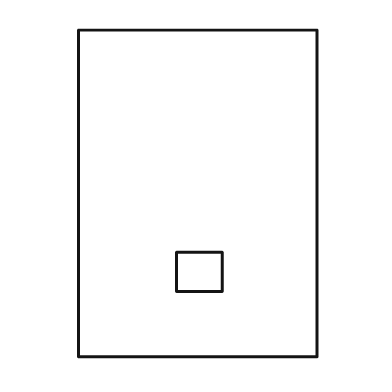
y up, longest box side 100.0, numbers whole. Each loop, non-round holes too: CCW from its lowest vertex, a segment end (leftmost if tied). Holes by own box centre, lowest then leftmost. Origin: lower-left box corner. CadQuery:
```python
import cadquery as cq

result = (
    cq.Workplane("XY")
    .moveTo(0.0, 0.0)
    .lineTo(73.0, 0.0)
    .lineTo(73.0, 100.0)
    .lineTo(0.0, 100.0)
    .close()
    .moveTo(30.0, 20.0)
    .lineTo(44.0, 20.0)
    .lineTo(44.0, 32.0)
    .lineTo(30.0, 32.0)
    .close()
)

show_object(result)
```